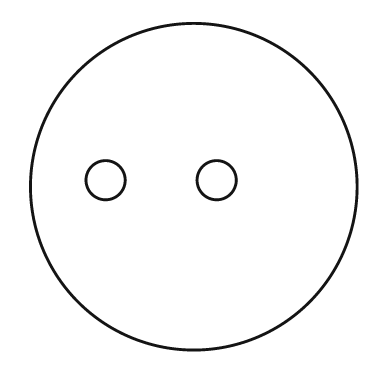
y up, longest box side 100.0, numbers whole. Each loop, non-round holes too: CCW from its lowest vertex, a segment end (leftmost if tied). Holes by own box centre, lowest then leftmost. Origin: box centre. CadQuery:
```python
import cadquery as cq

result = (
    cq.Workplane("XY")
    .moveTo(0.0, 0.0)
    .circle(50.0)
    .moveTo(-27.0, 2.0)
    .circle(6.0)
    .moveTo(7.0, 2.0)
    .circle(6.0)
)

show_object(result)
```